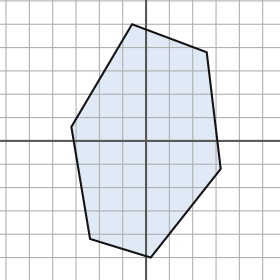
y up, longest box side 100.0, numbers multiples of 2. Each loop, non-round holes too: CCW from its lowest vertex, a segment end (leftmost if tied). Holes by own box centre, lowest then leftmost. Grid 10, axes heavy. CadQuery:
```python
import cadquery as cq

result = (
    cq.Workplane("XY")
    .moveTo(2.0, -50.0)
    .lineTo(32.0, -12.0)
    .lineTo(26.0, 38.0)
    .lineTo(-6.0, 50.0)
    .lineTo(-32.0, 6.0)
    .lineTo(-24.0, -42.0)
    .close()
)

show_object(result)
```